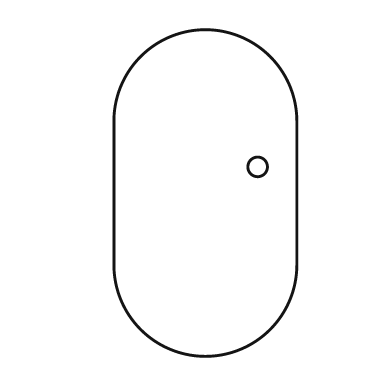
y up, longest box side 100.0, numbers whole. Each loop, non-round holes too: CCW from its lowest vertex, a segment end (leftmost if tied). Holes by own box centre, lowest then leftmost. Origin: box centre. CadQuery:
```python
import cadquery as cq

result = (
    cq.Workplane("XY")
    .moveTo(-28.0, -22.0)
    .threePointArc((0.0, -50.0), (28.0, -22.0))
    .lineTo(28.0, 22.0)
    .threePointArc((0.0, 50.0), (-28.0, 22.0))
    .close()
    .moveTo(16.0, 8.0)
    .circle(3.0)
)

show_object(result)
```